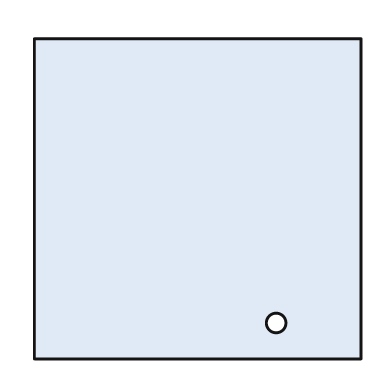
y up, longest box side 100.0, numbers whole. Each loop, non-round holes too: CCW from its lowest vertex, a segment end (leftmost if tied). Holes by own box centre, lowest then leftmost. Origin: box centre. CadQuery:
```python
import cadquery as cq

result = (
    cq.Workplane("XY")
    .moveTo(-50.0, -49.0)
    .lineTo(50.0, -49.0)
    .lineTo(50.0, 49.0)
    .lineTo(-50.0, 49.0)
    .close()
    .moveTo(24.0, -38.0)
    .circle(3.0)
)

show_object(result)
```